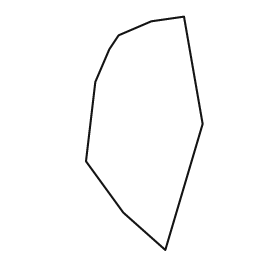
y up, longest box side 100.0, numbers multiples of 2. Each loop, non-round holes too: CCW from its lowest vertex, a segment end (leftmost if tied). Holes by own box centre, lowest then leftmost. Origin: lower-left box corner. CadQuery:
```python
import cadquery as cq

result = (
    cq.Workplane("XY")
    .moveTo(34.0, 0.0)
    .lineTo(50.0, 54.0)
    .lineTo(42.0, 100.0)
    .lineTo(28.0, 98.0)
    .lineTo(14.0, 92.0)
    .lineTo(10.0, 86.0)
    .lineTo(4.0, 72.0)
    .lineTo(0.0, 38.0)
    .lineTo(16.0, 16.0)
    .close()
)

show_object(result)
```